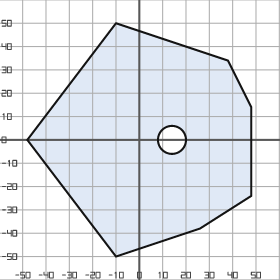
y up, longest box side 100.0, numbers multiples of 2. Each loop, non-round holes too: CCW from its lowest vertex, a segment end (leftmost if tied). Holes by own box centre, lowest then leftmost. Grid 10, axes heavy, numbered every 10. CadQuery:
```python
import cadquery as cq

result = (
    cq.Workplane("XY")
    .moveTo(-10.0, -50.0)
    .lineTo(26.0, -38.0)
    .lineTo(48.0, -24.0)
    .lineTo(48.0, 14.0)
    .lineTo(38.0, 34.0)
    .lineTo(-10.0, 50.0)
    .lineTo(-48.0, 0.0)
    .close()
    .moveTo(14.0, 0.0)
    .circle(6.0)
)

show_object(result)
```